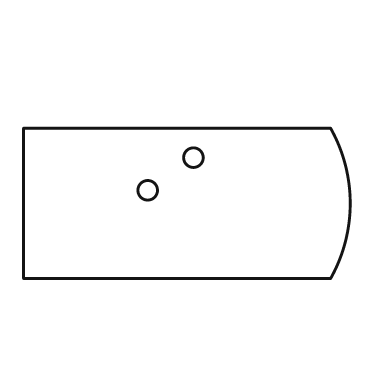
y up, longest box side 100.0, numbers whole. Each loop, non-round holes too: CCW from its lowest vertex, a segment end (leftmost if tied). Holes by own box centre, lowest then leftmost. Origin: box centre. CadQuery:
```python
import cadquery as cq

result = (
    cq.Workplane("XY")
    .moveTo(-50.0, -23.0)
    .lineTo(44.0, -23.0)
    .threePointArc((50.0, 0.0), (44.0, 23.0))
    .lineTo(-50.0, 23.0)
    .close()
    .moveTo(-12.0, 4.0)
    .circle(3.0)
    .moveTo(2.0, 14.0)
    .circle(3.0)
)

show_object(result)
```